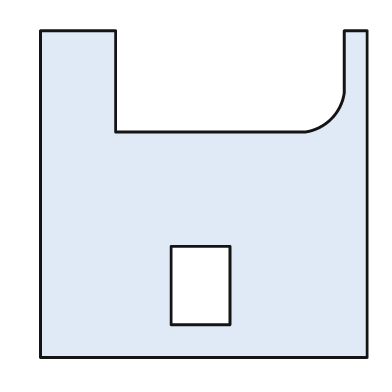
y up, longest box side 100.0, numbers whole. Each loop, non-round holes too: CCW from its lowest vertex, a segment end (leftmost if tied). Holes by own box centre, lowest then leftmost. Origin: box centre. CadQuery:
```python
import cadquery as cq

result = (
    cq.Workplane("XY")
    .moveTo(-50.0, -50.0)
    .lineTo(50.0, -50.0)
    .lineTo(50.0, 50.0)
    .lineTo(43.0, 50.0)
    .lineTo(43.0, 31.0)
    .threePointArc((39.0, 23.0), (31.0, 19.0))
    .lineTo(-27.0, 19.0)
    .lineTo(-27.0, 50.0)
    .lineTo(-50.0, 50.0)
    .close()
    .moveTo(-10.0, -40.0)
    .lineTo(8.0, -40.0)
    .lineTo(8.0, -16.0)
    .lineTo(-10.0, -16.0)
    .close()
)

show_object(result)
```